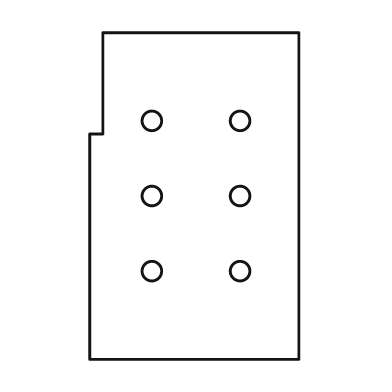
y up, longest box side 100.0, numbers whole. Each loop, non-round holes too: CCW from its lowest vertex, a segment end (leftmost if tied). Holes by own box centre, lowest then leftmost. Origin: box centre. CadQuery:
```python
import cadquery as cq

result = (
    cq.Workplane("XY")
    .moveTo(-32.0, -50.0)
    .lineTo(32.0, -50.0)
    .lineTo(32.0, 50.0)
    .lineTo(-28.0, 50.0)
    .lineTo(-28.0, 19.0)
    .lineTo(-32.0, 19.0)
    .close()
    .moveTo(-13.0, -23.0)
    .circle(3.0)
    .moveTo(14.0, -23.0)
    .circle(3.0)
    .moveTo(-13.0, 0.0)
    .circle(3.0)
    .moveTo(14.0, 0.0)
    .circle(3.0)
    .moveTo(-13.0, 23.0)
    .circle(3.0)
    .moveTo(14.0, 23.0)
    .circle(3.0)
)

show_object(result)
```